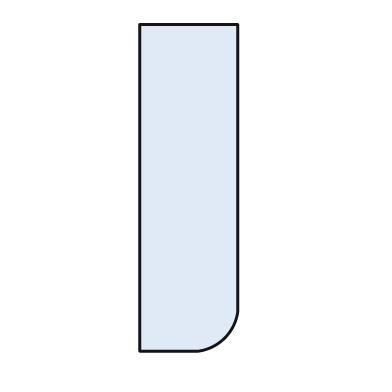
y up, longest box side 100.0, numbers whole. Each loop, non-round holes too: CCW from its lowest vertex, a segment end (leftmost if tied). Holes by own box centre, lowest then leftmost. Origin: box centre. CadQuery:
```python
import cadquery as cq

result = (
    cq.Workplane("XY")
    .moveTo(-15.0, -50.0)
    .lineTo(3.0, -50.0)
    .threePointArc((11.0, -46.0), (15.0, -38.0))
    .lineTo(15.0, 50.0)
    .lineTo(-15.0, 50.0)
    .close()
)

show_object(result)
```